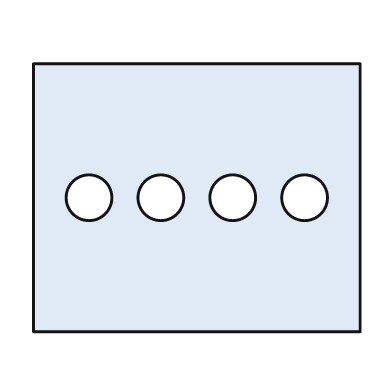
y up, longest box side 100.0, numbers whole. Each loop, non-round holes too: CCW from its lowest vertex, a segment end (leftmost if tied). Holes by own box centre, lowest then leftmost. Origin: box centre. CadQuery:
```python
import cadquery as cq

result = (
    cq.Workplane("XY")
    .moveTo(-50.0, -41.0)
    .lineTo(50.0, -41.0)
    .lineTo(50.0, 41.0)
    .lineTo(-50.0, 41.0)
    .close()
    .moveTo(-33.0, 0.0)
    .circle(7.0)
    .moveTo(-11.0, 0.0)
    .circle(7.0)
    .moveTo(11.0, 0.0)
    .circle(7.0)
    .moveTo(33.0, 0.0)
    .circle(7.0)
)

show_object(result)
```